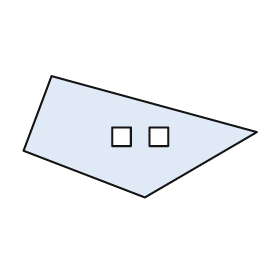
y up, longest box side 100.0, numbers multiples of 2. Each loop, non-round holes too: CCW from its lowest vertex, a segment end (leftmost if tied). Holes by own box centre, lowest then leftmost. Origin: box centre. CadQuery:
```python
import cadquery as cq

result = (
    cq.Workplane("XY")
    .moveTo(2.0, -26.0)
    .lineTo(50.0, 2.0)
    .lineTo(-38.0, 26.0)
    .lineTo(-50.0, -6.0)
    .close()
    .moveTo(-12.0, -4.0)
    .lineTo(-4.0, -4.0)
    .lineTo(-4.0, 4.0)
    .lineTo(-12.0, 4.0)
    .close()
    .moveTo(4.0, -4.0)
    .lineTo(12.0, -4.0)
    .lineTo(12.0, 4.0)
    .lineTo(4.0, 4.0)
    .close()
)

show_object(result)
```